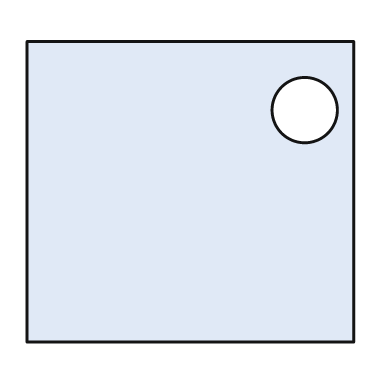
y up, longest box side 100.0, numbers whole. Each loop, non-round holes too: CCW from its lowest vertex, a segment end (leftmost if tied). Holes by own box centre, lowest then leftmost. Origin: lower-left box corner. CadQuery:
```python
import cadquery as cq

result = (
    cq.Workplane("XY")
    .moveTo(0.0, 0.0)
    .lineTo(100.0, 0.0)
    .lineTo(100.0, 92.0)
    .lineTo(0.0, 92.0)
    .close()
    .moveTo(85.0, 71.0)
    .circle(10.0)
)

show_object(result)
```